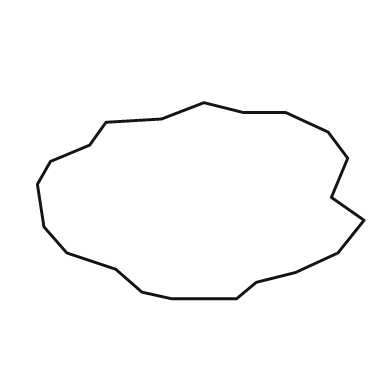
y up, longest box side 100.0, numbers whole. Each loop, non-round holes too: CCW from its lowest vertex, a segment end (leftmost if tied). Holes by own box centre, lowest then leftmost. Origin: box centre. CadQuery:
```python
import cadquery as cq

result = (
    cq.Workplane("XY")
    .moveTo(-9.0, -30.0)
    .lineTo(11.0, -30.0)
    .lineTo(17.0, -25.0)
    .lineTo(29.0, -22.0)
    .lineTo(42.0, -16.0)
    .lineTo(50.0, -6.0)
    .lineTo(40.0, 1.0)
    .lineTo(45.0, 13.0)
    .lineTo(39.0, 21.0)
    .lineTo(26.0, 27.0)
    .lineTo(13.0, 27.0)
    .lineTo(1.0, 30.0)
    .lineTo(-12.0, 25.0)
    .lineTo(-29.0, 24.0)
    .lineTo(-34.0, 17.0)
    .lineTo(-46.0, 12.0)
    .lineTo(-50.0, 5.0)
    .lineTo(-48.0, -8.0)
    .lineTo(-41.0, -16.0)
    .lineTo(-26.0, -21.0)
    .lineTo(-18.0, -28.0)
    .close()
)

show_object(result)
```